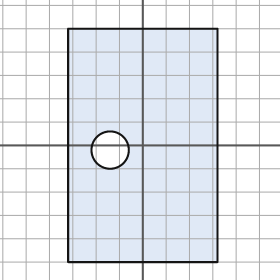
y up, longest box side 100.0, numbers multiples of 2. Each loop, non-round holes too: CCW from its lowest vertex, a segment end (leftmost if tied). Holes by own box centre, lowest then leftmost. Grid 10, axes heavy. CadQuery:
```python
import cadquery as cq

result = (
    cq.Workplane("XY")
    .moveTo(-32.0, -50.0)
    .lineTo(32.0, -50.0)
    .lineTo(32.0, 50.0)
    .lineTo(-32.0, 50.0)
    .close()
    .moveTo(-14.0, -2.0)
    .circle(8.0)
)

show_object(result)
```